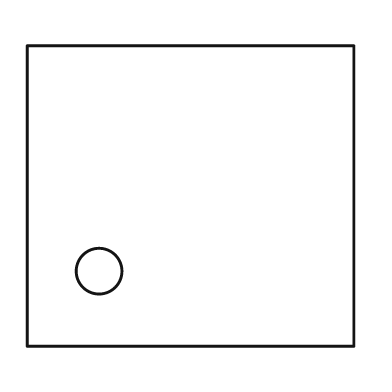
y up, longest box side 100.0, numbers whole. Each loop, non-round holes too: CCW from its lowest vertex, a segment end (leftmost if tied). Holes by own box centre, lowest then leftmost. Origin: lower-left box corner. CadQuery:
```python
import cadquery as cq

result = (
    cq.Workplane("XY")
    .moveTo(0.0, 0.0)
    .lineTo(100.0, 0.0)
    .lineTo(100.0, 92.0)
    .lineTo(0.0, 92.0)
    .close()
    .moveTo(22.0, 23.0)
    .circle(7.0)
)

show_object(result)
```